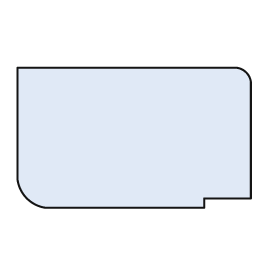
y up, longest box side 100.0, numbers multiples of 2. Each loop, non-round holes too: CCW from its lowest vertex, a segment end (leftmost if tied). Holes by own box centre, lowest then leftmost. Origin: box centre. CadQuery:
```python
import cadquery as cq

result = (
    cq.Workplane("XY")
    .moveTo(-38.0, -30.0)
    .lineTo(30.0, -30.0)
    .lineTo(30.0, -26.0)
    .lineTo(50.0, -26.0)
    .lineTo(50.0, 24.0)
    .threePointArc((48.0, 28.0), (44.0, 30.0))
    .lineTo(-50.0, 30.0)
    .lineTo(-50.0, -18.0)
    .threePointArc((-46.0, -26.0), (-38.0, -30.0))
    .close()
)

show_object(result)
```